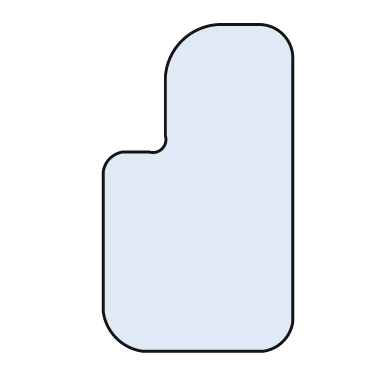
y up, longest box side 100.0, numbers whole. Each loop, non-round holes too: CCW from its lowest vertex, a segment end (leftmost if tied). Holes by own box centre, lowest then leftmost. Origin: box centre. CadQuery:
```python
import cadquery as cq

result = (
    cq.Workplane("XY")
    .moveTo(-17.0, -50.0)
    .lineTo(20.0, -50.0)
    .threePointArc((26.0, -47.0), (29.0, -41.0))
    .lineTo(29.0, 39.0)
    .threePointArc((26.0, 47.0), (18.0, 50.0))
    .lineTo(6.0, 50.0)
    .threePointArc((-5.0, 45.0), (-10.0, 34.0))
    .lineTo(-10.0, 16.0)
    .threePointArc((-11.0, 12.0), (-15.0, 11.0))
    .lineTo(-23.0, 11.0)
    .threePointArc((-27.0, 9.0), (-29.0, 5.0))
    .lineTo(-29.0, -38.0)
    .threePointArc((-25.0, -46.0), (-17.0, -50.0))
    .close()
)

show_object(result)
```